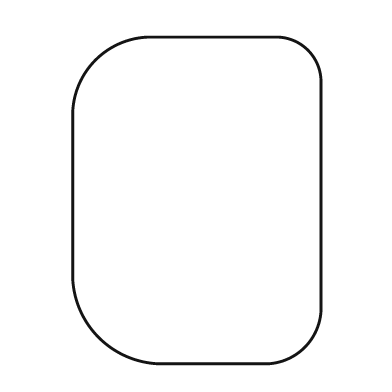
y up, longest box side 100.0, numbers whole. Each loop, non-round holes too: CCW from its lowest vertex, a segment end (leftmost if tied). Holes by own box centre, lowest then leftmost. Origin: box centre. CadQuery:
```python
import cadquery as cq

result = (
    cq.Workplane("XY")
    .moveTo(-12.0, -50.0)
    .lineTo(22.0, -50.0)
    .threePointArc((33.0, -45.0), (38.0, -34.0))
    .lineTo(38.0, 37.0)
    .threePointArc((34.0, 46.0), (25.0, 50.0))
    .lineTo(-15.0, 50.0)
    .threePointArc((-31.0, 43.0), (-38.0, 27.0))
    .lineTo(-38.0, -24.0)
    .threePointArc((-30.0, -42.0), (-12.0, -50.0))
    .close()
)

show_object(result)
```